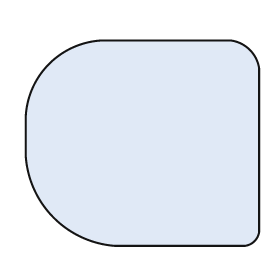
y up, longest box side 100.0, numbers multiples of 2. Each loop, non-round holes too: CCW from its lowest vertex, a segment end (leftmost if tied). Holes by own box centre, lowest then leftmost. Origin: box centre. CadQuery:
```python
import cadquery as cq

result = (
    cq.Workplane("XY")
    .moveTo(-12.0, -44.0)
    .lineTo(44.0, -44.0)
    .threePointArc((48.0, -42.0), (50.0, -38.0))
    .lineTo(50.0, 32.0)
    .threePointArc((46.0, 40.0), (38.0, 44.0))
    .lineTo(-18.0, 44.0)
    .threePointArc((-40.0, 34.0), (-50.0, 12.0))
    .lineTo(-50.0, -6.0)
    .threePointArc((-38.0, -32.0), (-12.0, -44.0))
    .close()
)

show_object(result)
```